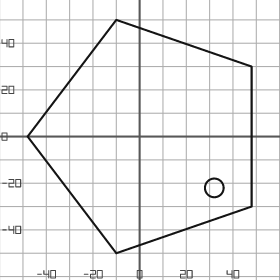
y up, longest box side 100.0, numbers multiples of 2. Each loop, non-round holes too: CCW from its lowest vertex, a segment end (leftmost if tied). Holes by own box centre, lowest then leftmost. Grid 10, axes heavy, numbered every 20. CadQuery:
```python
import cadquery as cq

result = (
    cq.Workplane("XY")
    .moveTo(-10.0, -50.0)
    .lineTo(48.0, -30.0)
    .lineTo(48.0, 30.0)
    .lineTo(-10.0, 50.0)
    .lineTo(-48.0, 0.0)
    .close()
    .moveTo(32.0, -22.0)
    .circle(4.0)
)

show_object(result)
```